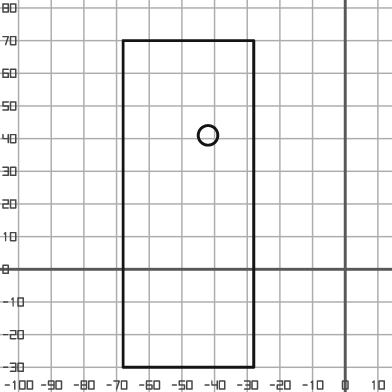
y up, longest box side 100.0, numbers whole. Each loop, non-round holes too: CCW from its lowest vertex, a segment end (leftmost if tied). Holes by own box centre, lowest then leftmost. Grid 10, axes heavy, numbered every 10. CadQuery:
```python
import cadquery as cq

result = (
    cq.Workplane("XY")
    .moveTo(-68.0, -30.0)
    .lineTo(-28.0, -30.0)
    .lineTo(-28.0, 70.0)
    .lineTo(-68.0, 70.0)
    .close()
    .moveTo(-42.0, 41.0)
    .circle(3.0)
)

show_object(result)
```